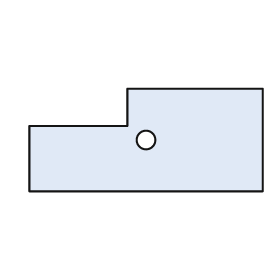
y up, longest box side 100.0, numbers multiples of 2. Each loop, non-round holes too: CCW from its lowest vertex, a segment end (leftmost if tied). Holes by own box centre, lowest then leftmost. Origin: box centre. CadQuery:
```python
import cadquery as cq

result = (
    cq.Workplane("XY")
    .moveTo(-50.0, -22.0)
    .lineTo(50.0, -22.0)
    .lineTo(50.0, 22.0)
    .lineTo(-8.0, 22.0)
    .lineTo(-8.0, 6.0)
    .lineTo(-50.0, 6.0)
    .close()
    .moveTo(0.0, 0.0)
    .circle(4.0)
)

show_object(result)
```